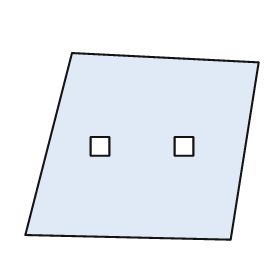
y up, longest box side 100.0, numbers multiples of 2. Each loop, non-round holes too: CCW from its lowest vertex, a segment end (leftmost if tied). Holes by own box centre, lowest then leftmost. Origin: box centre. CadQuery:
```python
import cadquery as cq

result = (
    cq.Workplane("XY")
    .moveTo(38.0, -40.0)
    .lineTo(50.0, 36.0)
    .lineTo(-30.0, 40.0)
    .lineTo(-50.0, -38.0)
    .close()
    .moveTo(-22.0, -4.0)
    .lineTo(-14.0, -4.0)
    .lineTo(-14.0, 4.0)
    .lineTo(-22.0, 4.0)
    .close()
    .moveTo(14.0, -4.0)
    .lineTo(22.0, -4.0)
    .lineTo(22.0, 4.0)
    .lineTo(14.0, 4.0)
    .close()
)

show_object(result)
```